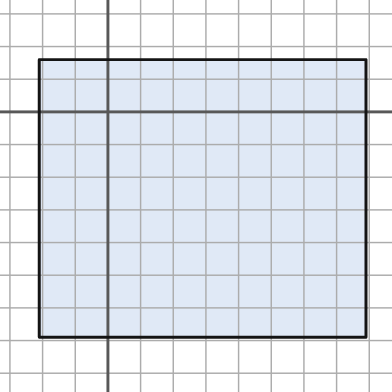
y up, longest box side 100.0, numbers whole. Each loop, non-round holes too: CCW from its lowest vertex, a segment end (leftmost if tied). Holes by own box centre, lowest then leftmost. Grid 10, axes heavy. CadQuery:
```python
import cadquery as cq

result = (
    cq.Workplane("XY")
    .moveTo(-21.0, -69.0)
    .lineTo(79.0, -69.0)
    .lineTo(79.0, 16.0)
    .lineTo(-21.0, 16.0)
    .close()
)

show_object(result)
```